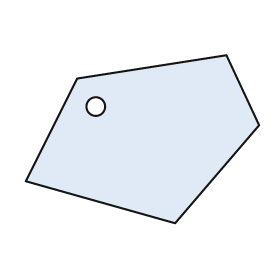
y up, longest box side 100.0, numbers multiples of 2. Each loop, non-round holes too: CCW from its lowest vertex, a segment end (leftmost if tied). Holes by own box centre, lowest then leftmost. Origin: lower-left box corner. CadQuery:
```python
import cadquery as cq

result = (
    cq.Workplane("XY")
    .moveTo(64.0, 0.0)
    .lineTo(100.0, 42.0)
    .lineTo(86.0, 72.0)
    .lineTo(22.0, 62.0)
    .lineTo(0.0, 18.0)
    .close()
    .moveTo(30.0, 50.0)
    .circle(4.0)
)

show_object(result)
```